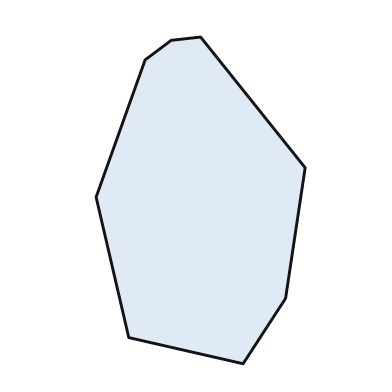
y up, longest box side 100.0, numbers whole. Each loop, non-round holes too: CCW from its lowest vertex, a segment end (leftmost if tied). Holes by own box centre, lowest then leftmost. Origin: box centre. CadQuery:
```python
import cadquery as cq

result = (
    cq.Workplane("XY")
    .moveTo(13.0, -50.0)
    .lineTo(26.0, -30.0)
    .lineTo(32.0, 10.0)
    .lineTo(0.0, 50.0)
    .lineTo(-9.0, 49.0)
    .lineTo(-17.0, 43.0)
    .lineTo(-32.0, 1.0)
    .lineTo(-22.0, -42.0)
    .close()
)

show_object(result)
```